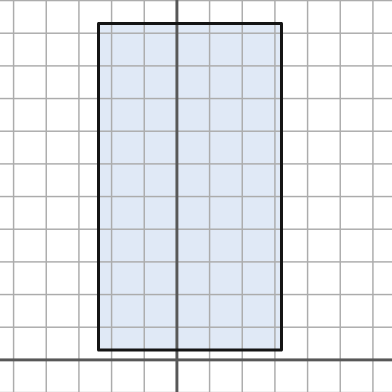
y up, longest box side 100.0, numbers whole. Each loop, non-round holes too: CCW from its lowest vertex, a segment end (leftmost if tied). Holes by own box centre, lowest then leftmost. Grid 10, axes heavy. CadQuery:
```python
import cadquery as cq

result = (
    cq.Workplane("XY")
    .moveTo(-24.0, 3.0)
    .lineTo(32.0, 3.0)
    .lineTo(32.0, 103.0)
    .lineTo(-24.0, 103.0)
    .close()
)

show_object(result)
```